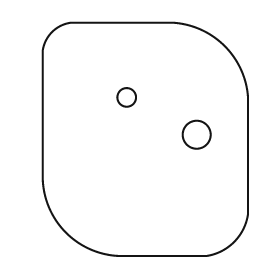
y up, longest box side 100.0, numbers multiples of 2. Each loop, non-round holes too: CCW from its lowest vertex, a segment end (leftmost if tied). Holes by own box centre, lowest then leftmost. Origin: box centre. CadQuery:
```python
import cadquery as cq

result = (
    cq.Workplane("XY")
    .moveTo(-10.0, -50.0)
    .lineTo(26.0, -50.0)
    .threePointArc((38.0, -44.0), (44.0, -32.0))
    .lineTo(44.0, 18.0)
    .threePointArc((34.0, 40.0), (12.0, 50.0))
    .lineTo(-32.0, 50.0)
    .threePointArc((-40.0, 46.0), (-44.0, 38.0))
    .lineTo(-44.0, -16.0)
    .threePointArc((-34.0, -40.0), (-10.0, -50.0))
    .close()
    .moveTo(22.0, 2.0)
    .circle(6.0)
    .moveTo(-8.0, 18.0)
    .circle(4.0)
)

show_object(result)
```